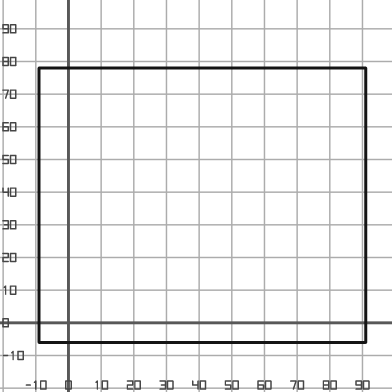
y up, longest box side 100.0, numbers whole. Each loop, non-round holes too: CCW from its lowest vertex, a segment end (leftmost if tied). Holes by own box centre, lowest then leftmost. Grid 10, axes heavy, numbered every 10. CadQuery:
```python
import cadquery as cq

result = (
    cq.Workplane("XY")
    .moveTo(-9.0, -6.0)
    .lineTo(91.0, -6.0)
    .lineTo(91.0, 78.0)
    .lineTo(-9.0, 78.0)
    .close()
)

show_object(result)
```